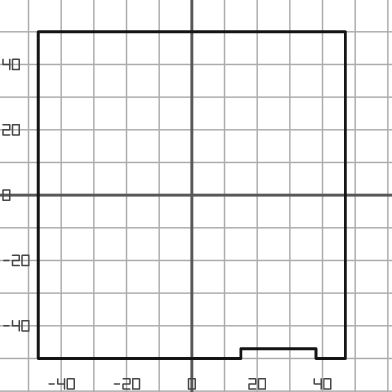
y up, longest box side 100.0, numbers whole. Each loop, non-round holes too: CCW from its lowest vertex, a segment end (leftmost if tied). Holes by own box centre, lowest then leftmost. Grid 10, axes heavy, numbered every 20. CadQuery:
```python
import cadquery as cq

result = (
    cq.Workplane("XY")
    .moveTo(-47.0, -50.0)
    .lineTo(15.0, -50.0)
    .lineTo(15.0, -47.0)
    .lineTo(38.0, -47.0)
    .lineTo(38.0, -50.0)
    .lineTo(47.0, -50.0)
    .lineTo(47.0, 50.0)
    .lineTo(-47.0, 50.0)
    .close()
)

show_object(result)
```